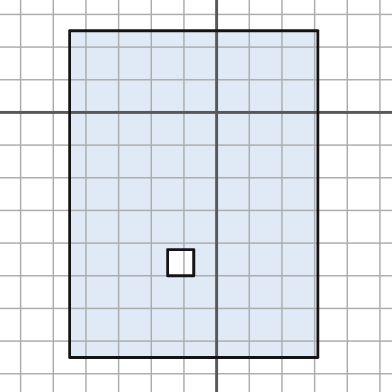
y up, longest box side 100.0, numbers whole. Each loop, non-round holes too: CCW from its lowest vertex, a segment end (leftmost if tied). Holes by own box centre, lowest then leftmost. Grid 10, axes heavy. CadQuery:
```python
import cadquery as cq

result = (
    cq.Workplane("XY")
    .moveTo(-45.0, -75.0)
    .lineTo(31.0, -75.0)
    .lineTo(31.0, 25.0)
    .lineTo(-45.0, 25.0)
    .close()
    .moveTo(-15.0, -50.0)
    .lineTo(-7.0, -50.0)
    .lineTo(-7.0, -42.0)
    .lineTo(-15.0, -42.0)
    .close()
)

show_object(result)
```